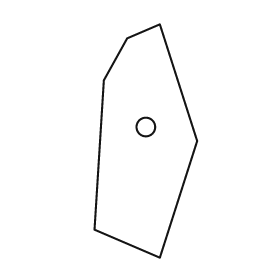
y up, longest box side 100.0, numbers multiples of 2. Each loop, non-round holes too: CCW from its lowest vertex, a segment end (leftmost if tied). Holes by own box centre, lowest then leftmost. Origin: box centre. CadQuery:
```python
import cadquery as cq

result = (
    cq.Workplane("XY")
    .moveTo(6.0, -50.0)
    .lineTo(22.0, 0.0)
    .lineTo(6.0, 50.0)
    .lineTo(-8.0, 44.0)
    .lineTo(-18.0, 26.0)
    .lineTo(-22.0, -38.0)
    .close()
    .moveTo(0.0, 6.0)
    .circle(4.0)
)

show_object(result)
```